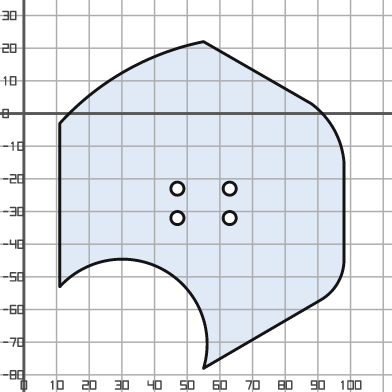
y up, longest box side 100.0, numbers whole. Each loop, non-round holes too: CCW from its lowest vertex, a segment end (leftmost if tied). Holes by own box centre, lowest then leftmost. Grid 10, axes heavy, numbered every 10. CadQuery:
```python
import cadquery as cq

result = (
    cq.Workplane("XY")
    .moveTo(55.0, -78.0)
    .lineTo(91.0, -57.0)
    .threePointArc((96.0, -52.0), (98.0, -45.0))
    .lineTo(98.0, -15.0)
    .threePointArc((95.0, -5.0), (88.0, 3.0))
    .lineTo(55.0, 22.0)
    .threePointArc((31.0, 13.0), (11.0, -3.0))
    .lineTo(11.0, -53.0)
    .threePointArc((43.0, -48.0), (55.0, -78.0))
    .close()
    .moveTo(47.0, -32.0)
    .circle(2.0)
    .moveTo(63.0, -32.0)
    .circle(2.0)
    .moveTo(47.0, -23.0)
    .circle(2.0)
    .moveTo(63.0, -23.0)
    .circle(2.0)
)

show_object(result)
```